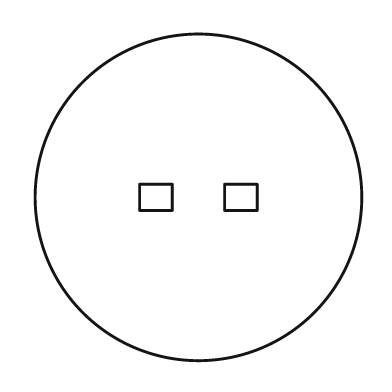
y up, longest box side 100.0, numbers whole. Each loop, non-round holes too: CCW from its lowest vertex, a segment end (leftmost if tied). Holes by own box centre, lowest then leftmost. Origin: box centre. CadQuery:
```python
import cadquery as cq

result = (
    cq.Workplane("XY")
    .moveTo(0.0, 0.0)
    .circle(50.0)
    .moveTo(-18.0, -4.0)
    .lineTo(-8.0, -4.0)
    .lineTo(-8.0, 4.0)
    .lineTo(-18.0, 4.0)
    .close()
    .moveTo(8.0, -4.0)
    .lineTo(18.0, -4.0)
    .lineTo(18.0, 4.0)
    .lineTo(8.0, 4.0)
    .close()
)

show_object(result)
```